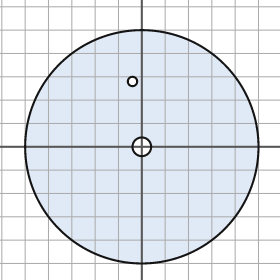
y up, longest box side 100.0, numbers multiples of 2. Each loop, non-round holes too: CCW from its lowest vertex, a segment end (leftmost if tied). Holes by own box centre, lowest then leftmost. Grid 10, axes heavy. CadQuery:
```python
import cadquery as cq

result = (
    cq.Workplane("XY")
    .moveTo(0.0, 0.0)
    .circle(50.0)
    .moveTo(0.0, 0.0)
    .circle(4.0)
    .moveTo(-4.0, 28.0)
    .circle(2.0)
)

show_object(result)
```